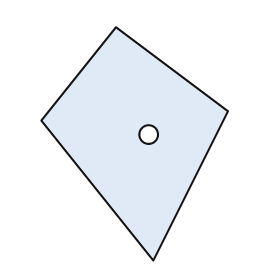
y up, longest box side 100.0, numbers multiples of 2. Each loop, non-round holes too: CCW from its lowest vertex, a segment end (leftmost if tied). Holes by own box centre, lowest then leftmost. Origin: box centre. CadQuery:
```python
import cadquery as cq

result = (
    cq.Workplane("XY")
    .moveTo(8.0, -50.0)
    .lineTo(40.0, 14.0)
    .lineTo(-8.0, 50.0)
    .lineTo(-40.0, 10.0)
    .close()
    .moveTo(6.0, 4.0)
    .circle(4.0)
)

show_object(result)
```